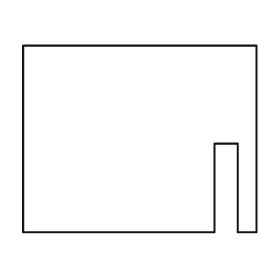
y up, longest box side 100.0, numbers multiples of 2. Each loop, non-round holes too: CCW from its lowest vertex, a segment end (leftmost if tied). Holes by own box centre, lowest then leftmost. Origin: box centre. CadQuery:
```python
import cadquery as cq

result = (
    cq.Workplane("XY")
    .moveTo(-50.0, -40.0)
    .lineTo(32.0, -40.0)
    .lineTo(32.0, -2.0)
    .lineTo(42.0, -2.0)
    .lineTo(42.0, -40.0)
    .lineTo(50.0, -40.0)
    .lineTo(50.0, 40.0)
    .lineTo(-50.0, 40.0)
    .close()
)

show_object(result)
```